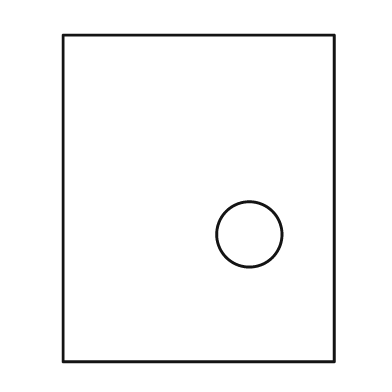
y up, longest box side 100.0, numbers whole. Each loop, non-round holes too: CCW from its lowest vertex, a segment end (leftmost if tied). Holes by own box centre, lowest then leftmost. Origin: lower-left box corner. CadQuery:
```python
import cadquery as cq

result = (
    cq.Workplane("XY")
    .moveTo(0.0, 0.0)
    .lineTo(83.0, 0.0)
    .lineTo(83.0, 100.0)
    .lineTo(0.0, 100.0)
    .close()
    .moveTo(57.0, 39.0)
    .circle(10.0)
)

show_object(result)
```